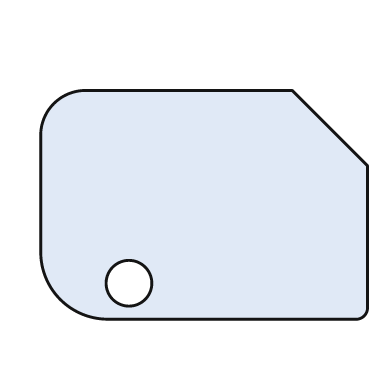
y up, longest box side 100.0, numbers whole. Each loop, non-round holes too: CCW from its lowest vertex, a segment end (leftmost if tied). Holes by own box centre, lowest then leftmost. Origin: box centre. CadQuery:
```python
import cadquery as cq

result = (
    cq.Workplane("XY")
    .moveTo(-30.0, -35.0)
    .lineTo(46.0, -35.0)
    .threePointArc((49.0, -34.0), (50.0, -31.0))
    .lineTo(50.0, 12.0)
    .lineTo(27.0, 35.0)
    .lineTo(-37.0, 35.0)
    .threePointArc((-46.0, 31.0), (-50.0, 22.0))
    .lineTo(-50.0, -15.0)
    .threePointArc((-44.0, -29.0), (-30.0, -35.0))
    .close()
    .moveTo(-23.0, -24.0)
    .circle(7.0)
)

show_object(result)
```